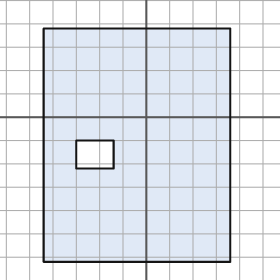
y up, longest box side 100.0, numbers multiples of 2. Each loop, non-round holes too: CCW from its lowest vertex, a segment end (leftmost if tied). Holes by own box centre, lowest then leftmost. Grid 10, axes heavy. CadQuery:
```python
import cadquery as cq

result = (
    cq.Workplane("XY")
    .moveTo(-44.0, -62.0)
    .lineTo(36.0, -62.0)
    .lineTo(36.0, 38.0)
    .lineTo(-44.0, 38.0)
    .close()
    .moveTo(-30.0, -22.0)
    .lineTo(-14.0, -22.0)
    .lineTo(-14.0, -10.0)
    .lineTo(-30.0, -10.0)
    .close()
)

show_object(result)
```